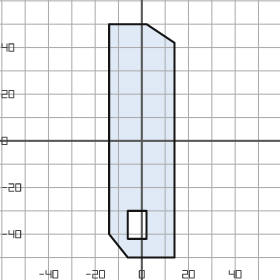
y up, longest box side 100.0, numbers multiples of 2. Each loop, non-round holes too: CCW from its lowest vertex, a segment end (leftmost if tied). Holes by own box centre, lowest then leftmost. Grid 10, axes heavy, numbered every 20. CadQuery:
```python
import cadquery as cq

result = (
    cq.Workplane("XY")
    .moveTo(-6.0, -50.0)
    .lineTo(14.0, -50.0)
    .lineTo(14.0, 42.0)
    .lineTo(2.0, 50.0)
    .lineTo(-14.0, 50.0)
    .lineTo(-14.0, -40.0)
    .close()
    .moveTo(-6.0, -42.0)
    .lineTo(2.0, -42.0)
    .lineTo(2.0, -30.0)
    .lineTo(-6.0, -30.0)
    .close()
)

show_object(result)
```